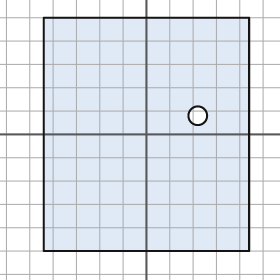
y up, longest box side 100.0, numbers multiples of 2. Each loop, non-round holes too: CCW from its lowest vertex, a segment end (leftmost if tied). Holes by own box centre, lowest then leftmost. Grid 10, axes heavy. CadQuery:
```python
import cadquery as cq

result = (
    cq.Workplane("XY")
    .moveTo(-44.0, -50.0)
    .lineTo(44.0, -50.0)
    .lineTo(44.0, 50.0)
    .lineTo(-44.0, 50.0)
    .close()
    .moveTo(22.0, 8.0)
    .circle(4.0)
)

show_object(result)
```